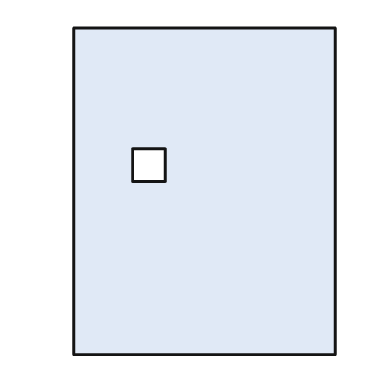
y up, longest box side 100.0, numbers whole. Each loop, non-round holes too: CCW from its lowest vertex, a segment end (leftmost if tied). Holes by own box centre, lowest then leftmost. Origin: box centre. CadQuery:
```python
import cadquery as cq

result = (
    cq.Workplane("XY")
    .moveTo(-40.0, -50.0)
    .lineTo(40.0, -50.0)
    .lineTo(40.0, 50.0)
    .lineTo(-40.0, 50.0)
    .close()
    .moveTo(-22.0, 3.0)
    .lineTo(-12.0, 3.0)
    .lineTo(-12.0, 13.0)
    .lineTo(-22.0, 13.0)
    .close()
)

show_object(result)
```